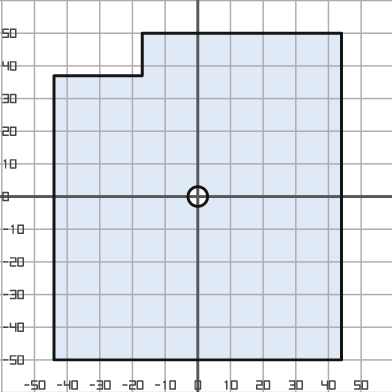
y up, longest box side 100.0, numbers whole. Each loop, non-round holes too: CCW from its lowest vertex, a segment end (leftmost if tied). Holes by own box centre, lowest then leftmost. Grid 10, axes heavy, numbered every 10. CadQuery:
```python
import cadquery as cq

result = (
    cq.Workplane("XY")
    .moveTo(-44.0, -50.0)
    .lineTo(44.0, -50.0)
    .lineTo(44.0, 50.0)
    .lineTo(-17.0, 50.0)
    .lineTo(-17.0, 37.0)
    .lineTo(-44.0, 37.0)
    .close()
    .moveTo(0.0, 0.0)
    .circle(3.0)
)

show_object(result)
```